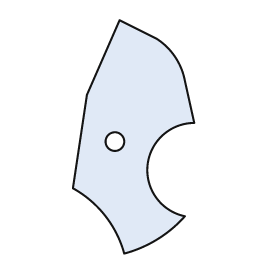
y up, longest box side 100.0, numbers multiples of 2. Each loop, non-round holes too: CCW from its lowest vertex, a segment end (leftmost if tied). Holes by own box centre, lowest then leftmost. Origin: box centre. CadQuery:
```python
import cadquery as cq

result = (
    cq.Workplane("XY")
    .moveTo(-4.0, -50.0)
    .threePointArc((10.0, -44.0), (22.0, -34.0))
    .threePointArc((6.0, -12.0), (26.0, 6.0))
    .lineTo(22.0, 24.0)
    .threePointArc((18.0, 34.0), (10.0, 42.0))
    .lineTo(-6.0, 50.0)
    .lineTo(-20.0, 18.0)
    .lineTo(-26.0, -22.0)
    .threePointArc((-12.0, -34.0), (-4.0, -50.0))
    .close()
    .moveTo(-8.0, -2.0)
    .circle(4.0)
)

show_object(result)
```